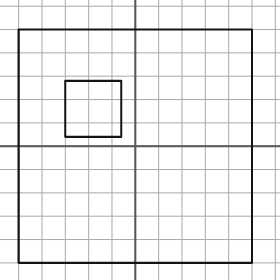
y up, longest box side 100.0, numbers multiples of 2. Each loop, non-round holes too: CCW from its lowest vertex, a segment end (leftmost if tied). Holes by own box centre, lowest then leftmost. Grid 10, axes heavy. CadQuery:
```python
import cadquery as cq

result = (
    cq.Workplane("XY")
    .moveTo(-50.0, -50.0)
    .lineTo(50.0, -50.0)
    .lineTo(50.0, 50.0)
    .lineTo(-50.0, 50.0)
    .close()
    .moveTo(-30.0, 4.0)
    .lineTo(-6.0, 4.0)
    .lineTo(-6.0, 28.0)
    .lineTo(-30.0, 28.0)
    .close()
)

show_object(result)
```